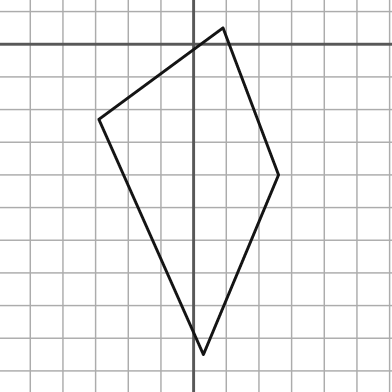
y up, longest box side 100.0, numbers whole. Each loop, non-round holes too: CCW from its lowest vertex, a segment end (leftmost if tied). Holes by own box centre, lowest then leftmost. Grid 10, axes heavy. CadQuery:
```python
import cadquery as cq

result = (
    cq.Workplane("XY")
    .moveTo(3.0, -95.0)
    .lineTo(26.0, -40.0)
    .lineTo(9.0, 5.0)
    .lineTo(-29.0, -23.0)
    .close()
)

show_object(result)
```